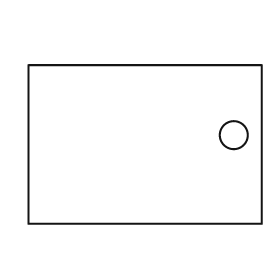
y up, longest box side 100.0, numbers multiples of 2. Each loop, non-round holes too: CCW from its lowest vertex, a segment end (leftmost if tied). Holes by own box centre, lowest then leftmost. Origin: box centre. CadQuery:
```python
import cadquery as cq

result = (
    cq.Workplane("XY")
    .moveTo(-50.0, -34.0)
    .lineTo(50.0, -34.0)
    .lineTo(50.0, 34.0)
    .lineTo(-50.0, 34.0)
    .close()
    .moveTo(38.0, 4.0)
    .circle(6.0)
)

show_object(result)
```